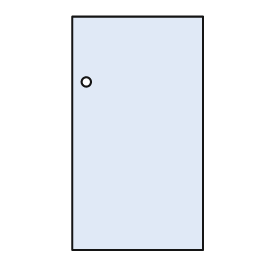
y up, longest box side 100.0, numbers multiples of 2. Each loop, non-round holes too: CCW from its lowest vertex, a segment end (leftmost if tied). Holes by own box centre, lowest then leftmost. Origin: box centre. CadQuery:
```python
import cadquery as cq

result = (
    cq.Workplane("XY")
    .moveTo(-28.0, -50.0)
    .lineTo(28.0, -50.0)
    .lineTo(28.0, 50.0)
    .lineTo(-28.0, 50.0)
    .close()
    .moveTo(-22.0, 22.0)
    .circle(2.0)
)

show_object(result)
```